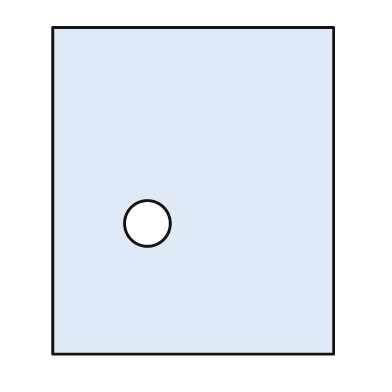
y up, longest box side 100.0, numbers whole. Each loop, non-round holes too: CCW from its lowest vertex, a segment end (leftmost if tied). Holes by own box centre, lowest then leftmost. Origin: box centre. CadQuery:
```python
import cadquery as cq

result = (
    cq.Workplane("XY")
    .moveTo(-43.0, -50.0)
    .lineTo(43.0, -50.0)
    .lineTo(43.0, 50.0)
    .lineTo(-43.0, 50.0)
    .close()
    .moveTo(-14.0, -10.0)
    .circle(7.0)
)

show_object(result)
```